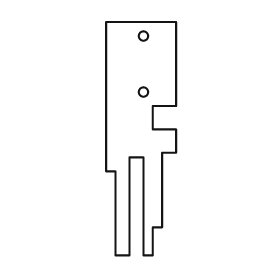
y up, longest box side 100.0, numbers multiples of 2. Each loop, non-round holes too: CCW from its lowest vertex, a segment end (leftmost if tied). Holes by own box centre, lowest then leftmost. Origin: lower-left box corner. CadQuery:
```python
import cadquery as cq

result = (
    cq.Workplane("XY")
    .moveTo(4.0, 0.0)
    .lineTo(10.0, 0.0)
    .lineTo(10.0, 42.0)
    .lineTo(16.0, 42.0)
    .lineTo(16.0, 0.0)
    .lineTo(20.0, 0.0)
    .lineTo(20.0, 12.0)
    .lineTo(24.0, 12.0)
    .lineTo(24.0, 44.0)
    .lineTo(30.0, 44.0)
    .lineTo(30.0, 54.0)
    .lineTo(20.0, 54.0)
    .lineTo(20.0, 64.0)
    .lineTo(30.0, 64.0)
    .lineTo(30.0, 100.0)
    .lineTo(0.0, 100.0)
    .lineTo(0.0, 36.0)
    .lineTo(4.0, 36.0)
    .close()
    .moveTo(16.0, 70.0)
    .circle(2.0)
    .moveTo(16.0, 94.0)
    .circle(2.0)
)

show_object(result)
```